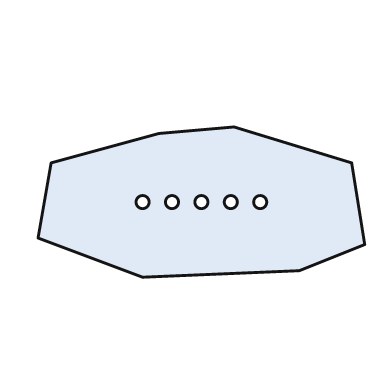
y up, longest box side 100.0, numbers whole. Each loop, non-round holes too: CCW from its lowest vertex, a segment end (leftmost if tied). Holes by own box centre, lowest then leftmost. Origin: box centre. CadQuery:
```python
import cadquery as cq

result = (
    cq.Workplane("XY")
    .moveTo(-18.0, -23.0)
    .lineTo(30.0, -21.0)
    .lineTo(50.0, -13.0)
    .lineTo(46.0, 12.0)
    .lineTo(10.0, 23.0)
    .lineTo(-13.0, 21.0)
    .lineTo(-46.0, 12.0)
    .lineTo(-50.0, -11.0)
    .close()
    .moveTo(-18.0, 0.0)
    .circle(2.0)
    .moveTo(-9.0, 0.0)
    .circle(2.0)
    .moveTo(0.0, 0.0)
    .circle(2.0)
    .moveTo(9.0, 0.0)
    .circle(2.0)
    .moveTo(18.0, 0.0)
    .circle(2.0)
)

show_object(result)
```